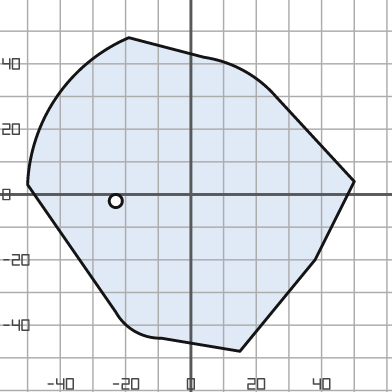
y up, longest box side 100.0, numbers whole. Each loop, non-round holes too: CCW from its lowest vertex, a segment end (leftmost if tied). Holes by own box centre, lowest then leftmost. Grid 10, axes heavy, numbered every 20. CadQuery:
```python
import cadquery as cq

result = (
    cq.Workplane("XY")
    .moveTo(15.0, -48.0)
    .lineTo(38.0, -20.0)
    .lineTo(50.0, 4.0)
    .lineTo(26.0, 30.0)
    .threePointArc((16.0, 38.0), (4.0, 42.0))
    .lineTo(-19.0, 48.0)
    .threePointArc((-41.0, 30.0), (-50.0, 3.0))
    .lineTo(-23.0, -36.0)
    .threePointArc((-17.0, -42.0), (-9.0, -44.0))
    .close()
    .moveTo(-23.0, -2.0)
    .circle(2.0)
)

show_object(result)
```